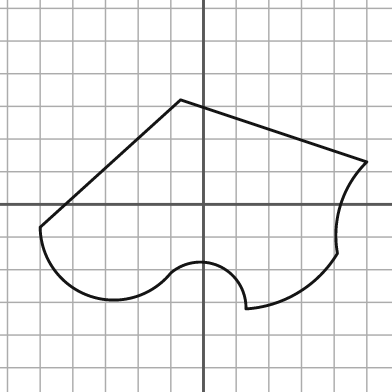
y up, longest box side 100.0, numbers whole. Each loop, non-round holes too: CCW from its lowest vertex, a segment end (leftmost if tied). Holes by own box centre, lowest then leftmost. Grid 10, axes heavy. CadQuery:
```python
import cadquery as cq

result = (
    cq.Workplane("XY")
    .moveTo(13.0, -32.0)
    .threePointArc((29.0, -27.0), (41.0, -15.0))
    .threePointArc((42.0, 0.0), (50.0, 13.0))
    .lineTo(-7.0, 32.0)
    .lineTo(-50.0, -7.0)
    .threePointArc((-35.0, -28.0), (-10.0, -21.0))
    .threePointArc((5.0, -19.0), (13.0, -32.0))
    .close()
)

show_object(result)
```